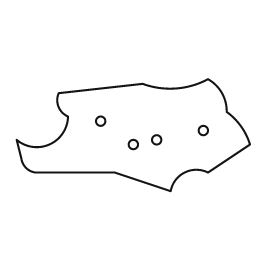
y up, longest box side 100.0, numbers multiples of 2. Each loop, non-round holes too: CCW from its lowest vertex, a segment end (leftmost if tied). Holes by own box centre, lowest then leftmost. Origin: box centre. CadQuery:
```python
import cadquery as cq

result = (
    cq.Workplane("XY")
    .moveTo(16.0, -24.0)
    .threePointArc((22.0, -16.0), (32.0, -16.0))
    .lineTo(50.0, -4.0)
    .threePointArc((46.0, 4.0), (40.0, 10.0))
    .threePointArc((38.0, 18.0), (32.0, 24.0))
    .threePointArc((18.0, 20.0), (4.0, 22.0))
    .lineTo(-32.0, 18.0)
    .threePointArc((-32.0, 12.0), (-28.0, 8.0))
    .threePointArc((-36.0, -4.0), (-50.0, -2.0))
    .lineTo(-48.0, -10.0)
    .threePointArc((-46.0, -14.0), (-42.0, -16.0))
    .lineTo(-8.0, -16.0)
    .close()
    .moveTo(0.0, -4.0)
    .circle(2.0)
    .moveTo(10.0, -2.0)
    .circle(2.0)
    .moveTo(30.0, 2.0)
    .circle(2.0)
    .moveTo(-14.0, 6.0)
    .circle(2.0)
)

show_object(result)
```